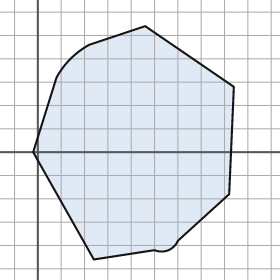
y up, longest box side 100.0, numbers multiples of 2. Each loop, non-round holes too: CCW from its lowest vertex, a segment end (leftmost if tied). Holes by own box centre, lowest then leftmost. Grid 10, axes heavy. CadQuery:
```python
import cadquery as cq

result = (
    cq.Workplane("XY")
    .moveTo(24.0, -46.0)
    .lineTo(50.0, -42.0)
    .threePointArc((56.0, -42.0), (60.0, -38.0))
    .lineTo(82.0, -18.0)
    .lineTo(84.0, 28.0)
    .lineTo(46.0, 54.0)
    .lineTo(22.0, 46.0)
    .threePointArc((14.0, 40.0), (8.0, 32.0))
    .lineTo(-2.0, 0.0)
    .close()
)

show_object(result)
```